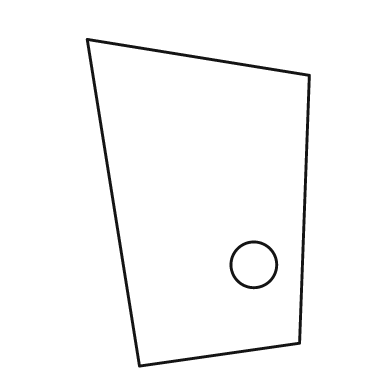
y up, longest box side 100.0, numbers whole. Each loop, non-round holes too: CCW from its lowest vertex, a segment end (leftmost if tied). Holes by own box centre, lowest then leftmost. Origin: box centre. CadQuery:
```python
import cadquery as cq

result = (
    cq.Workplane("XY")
    .moveTo(-18.0, -50.0)
    .lineTo(31.0, -43.0)
    .lineTo(34.0, 39.0)
    .lineTo(-34.0, 50.0)
    .close()
    .moveTo(17.0, -19.0)
    .circle(7.0)
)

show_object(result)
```